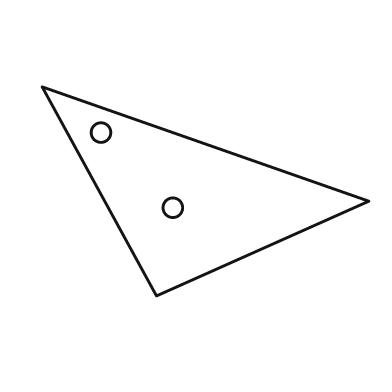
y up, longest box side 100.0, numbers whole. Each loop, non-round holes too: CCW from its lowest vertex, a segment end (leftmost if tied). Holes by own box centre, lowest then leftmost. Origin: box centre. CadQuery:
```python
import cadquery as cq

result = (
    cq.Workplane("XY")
    .moveTo(-15.0, -32.0)
    .lineTo(50.0, -3.0)
    .lineTo(-50.0, 32.0)
    .close()
    .moveTo(-10.0, -5.0)
    .circle(3.0)
    .moveTo(-32.0, 18.0)
    .circle(3.0)
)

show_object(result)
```